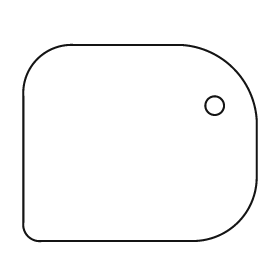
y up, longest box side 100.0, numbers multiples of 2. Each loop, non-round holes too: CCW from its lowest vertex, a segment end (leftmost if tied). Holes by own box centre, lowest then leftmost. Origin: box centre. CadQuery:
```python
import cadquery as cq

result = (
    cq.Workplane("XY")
    .moveTo(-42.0, -42.0)
    .lineTo(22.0, -42.0)
    .threePointArc((42.0, -34.0), (50.0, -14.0))
    .lineTo(50.0, 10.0)
    .threePointArc((40.0, 32.0), (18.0, 42.0))
    .lineTo(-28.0, 42.0)
    .threePointArc((-44.0, 36.0), (-50.0, 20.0))
    .lineTo(-50.0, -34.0)
    .threePointArc((-48.0, -40.0), (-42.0, -42.0))
    .close()
    .moveTo(32.0, 16.0)
    .circle(4.0)
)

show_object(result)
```